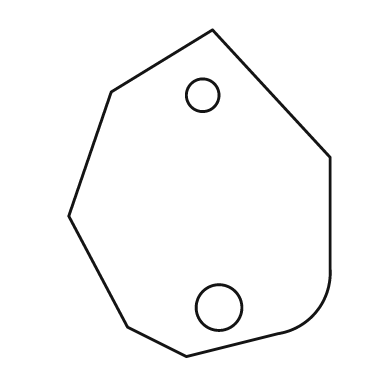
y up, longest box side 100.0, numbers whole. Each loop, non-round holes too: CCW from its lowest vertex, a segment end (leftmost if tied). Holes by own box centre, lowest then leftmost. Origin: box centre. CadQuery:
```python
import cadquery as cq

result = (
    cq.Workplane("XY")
    .moveTo(-4.0, -50.0)
    .lineTo(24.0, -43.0)
    .threePointArc((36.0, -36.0), (40.0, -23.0))
    .lineTo(40.0, 11.0)
    .lineTo(4.0, 50.0)
    .lineTo(-27.0, 31.0)
    .lineTo(-40.0, -7.0)
    .lineTo(-22.0, -41.0)
    .close()
    .moveTo(6.0, -35.0)
    .circle(7.0)
    .moveTo(1.0, 30.0)
    .circle(5.0)
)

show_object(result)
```